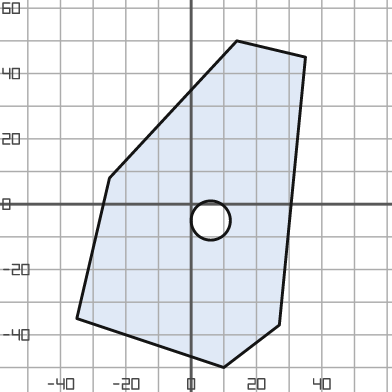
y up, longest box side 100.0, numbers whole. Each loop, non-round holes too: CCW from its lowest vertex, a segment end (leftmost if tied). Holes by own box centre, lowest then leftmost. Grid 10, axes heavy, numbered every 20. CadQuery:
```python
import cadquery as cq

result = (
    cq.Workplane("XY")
    .moveTo(10.0, -50.0)
    .lineTo(27.0, -37.0)
    .lineTo(35.0, 45.0)
    .lineTo(14.0, 50.0)
    .lineTo(-25.0, 8.0)
    .lineTo(-35.0, -35.0)
    .close()
    .moveTo(6.0, -5.0)
    .circle(6.0)
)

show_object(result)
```